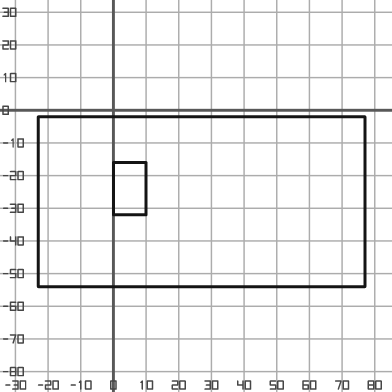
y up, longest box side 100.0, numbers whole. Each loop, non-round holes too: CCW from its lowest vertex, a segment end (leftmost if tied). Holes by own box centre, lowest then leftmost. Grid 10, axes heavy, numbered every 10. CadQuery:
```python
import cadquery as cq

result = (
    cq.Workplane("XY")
    .moveTo(-23.0, -54.0)
    .lineTo(77.0, -54.0)
    .lineTo(77.0, -2.0)
    .lineTo(-23.0, -2.0)
    .close()
    .moveTo(0.0, -32.0)
    .lineTo(10.0, -32.0)
    .lineTo(10.0, -16.0)
    .lineTo(0.0, -16.0)
    .close()
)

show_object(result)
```